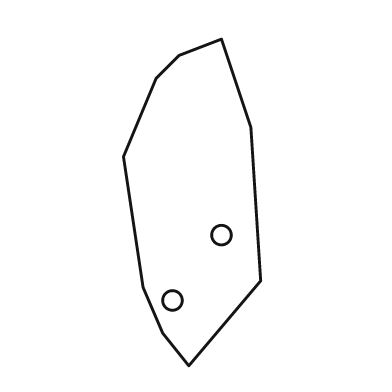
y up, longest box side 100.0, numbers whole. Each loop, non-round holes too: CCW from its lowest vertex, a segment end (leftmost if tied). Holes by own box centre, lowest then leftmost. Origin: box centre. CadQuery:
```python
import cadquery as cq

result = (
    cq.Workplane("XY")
    .moveTo(-1.0, -50.0)
    .lineTo(21.0, -24.0)
    .lineTo(18.0, 23.0)
    .lineTo(9.0, 50.0)
    .lineTo(-4.0, 45.0)
    .lineTo(-11.0, 38.0)
    .lineTo(-21.0, 14.0)
    .lineTo(-15.0, -26.0)
    .lineTo(-9.0, -40.0)
    .close()
    .moveTo(-6.0, -30.0)
    .circle(3.0)
    .moveTo(9.0, -10.0)
    .circle(3.0)
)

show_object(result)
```